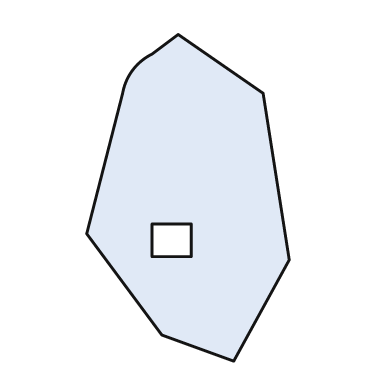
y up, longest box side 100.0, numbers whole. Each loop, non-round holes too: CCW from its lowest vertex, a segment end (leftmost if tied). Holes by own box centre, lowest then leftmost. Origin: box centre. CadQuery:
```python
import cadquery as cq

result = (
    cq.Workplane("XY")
    .moveTo(14.0, -50.0)
    .lineTo(31.0, -19.0)
    .lineTo(23.0, 32.0)
    .lineTo(-3.0, 50.0)
    .lineTo(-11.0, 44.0)
    .threePointArc((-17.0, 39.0), (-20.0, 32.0))
    .lineTo(-31.0, -11.0)
    .lineTo(-8.0, -42.0)
    .close()
    .moveTo(-11.0, -18.0)
    .lineTo(1.0, -18.0)
    .lineTo(1.0, -8.0)
    .lineTo(-11.0, -8.0)
    .close()
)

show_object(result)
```